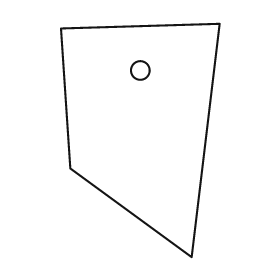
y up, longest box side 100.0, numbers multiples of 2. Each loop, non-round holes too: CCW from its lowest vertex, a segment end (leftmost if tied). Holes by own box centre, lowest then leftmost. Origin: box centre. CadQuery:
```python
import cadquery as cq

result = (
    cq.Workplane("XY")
    .moveTo(22.0, -50.0)
    .lineTo(34.0, 50.0)
    .lineTo(-34.0, 48.0)
    .lineTo(-30.0, -12.0)
    .close()
    .moveTo(0.0, 30.0)
    .circle(4.0)
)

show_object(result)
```